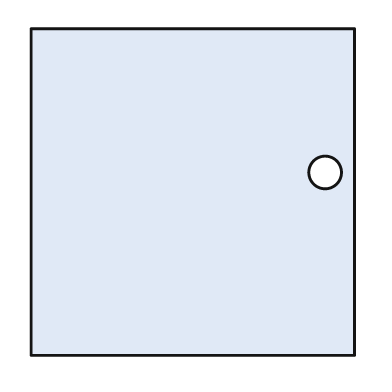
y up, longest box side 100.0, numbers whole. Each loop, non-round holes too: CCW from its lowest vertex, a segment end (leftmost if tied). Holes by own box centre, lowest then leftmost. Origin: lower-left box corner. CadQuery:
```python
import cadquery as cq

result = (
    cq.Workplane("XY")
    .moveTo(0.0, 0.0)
    .lineTo(99.0, 0.0)
    .lineTo(99.0, 100.0)
    .lineTo(0.0, 100.0)
    .close()
    .moveTo(90.0, 56.0)
    .circle(5.0)
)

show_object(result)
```